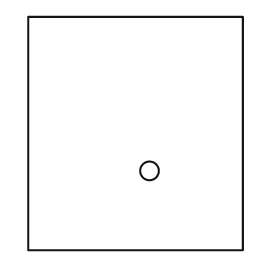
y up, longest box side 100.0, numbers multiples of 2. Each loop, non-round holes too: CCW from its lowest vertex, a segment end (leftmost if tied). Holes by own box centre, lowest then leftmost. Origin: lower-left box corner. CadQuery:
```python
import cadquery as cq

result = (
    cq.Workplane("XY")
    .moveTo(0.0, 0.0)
    .lineTo(92.0, 0.0)
    .lineTo(92.0, 100.0)
    .lineTo(0.0, 100.0)
    .close()
    .moveTo(52.0, 34.0)
    .circle(4.0)
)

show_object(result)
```